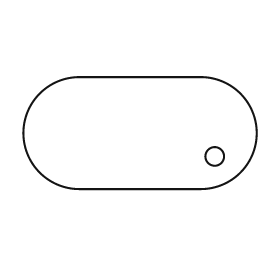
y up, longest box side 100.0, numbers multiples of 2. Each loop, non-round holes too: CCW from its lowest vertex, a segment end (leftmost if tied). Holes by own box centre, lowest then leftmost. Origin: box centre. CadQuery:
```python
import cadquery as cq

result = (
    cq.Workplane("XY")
    .moveTo(-26.0, -24.0)
    .lineTo(26.0, -24.0)
    .threePointArc((50.0, 0.0), (26.0, 24.0))
    .lineTo(-26.0, 24.0)
    .threePointArc((-50.0, 0.0), (-26.0, -24.0))
    .close()
    .moveTo(32.0, -10.0)
    .circle(4.0)
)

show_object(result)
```